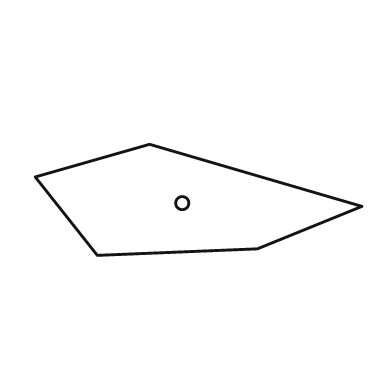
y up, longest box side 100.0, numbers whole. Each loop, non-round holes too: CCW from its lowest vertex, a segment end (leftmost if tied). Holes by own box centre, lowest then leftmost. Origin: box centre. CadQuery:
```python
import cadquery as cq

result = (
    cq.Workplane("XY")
    .moveTo(-31.0, -17.0)
    .lineTo(18.0, -15.0)
    .lineTo(50.0, -2.0)
    .lineTo(-15.0, 17.0)
    .lineTo(-50.0, 7.0)
    .close()
    .moveTo(-5.0, -1.0)
    .circle(2.0)
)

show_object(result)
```